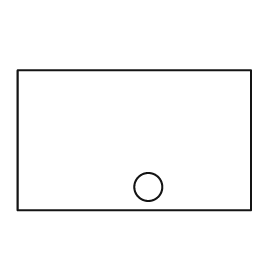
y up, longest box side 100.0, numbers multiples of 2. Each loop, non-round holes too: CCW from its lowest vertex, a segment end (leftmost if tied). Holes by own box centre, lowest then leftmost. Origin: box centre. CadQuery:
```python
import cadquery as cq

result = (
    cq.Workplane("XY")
    .moveTo(-50.0, -30.0)
    .lineTo(50.0, -30.0)
    .lineTo(50.0, 30.0)
    .lineTo(-50.0, 30.0)
    .close()
    .moveTo(6.0, -20.0)
    .circle(6.0)
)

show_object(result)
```